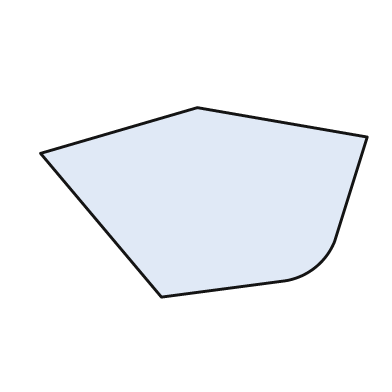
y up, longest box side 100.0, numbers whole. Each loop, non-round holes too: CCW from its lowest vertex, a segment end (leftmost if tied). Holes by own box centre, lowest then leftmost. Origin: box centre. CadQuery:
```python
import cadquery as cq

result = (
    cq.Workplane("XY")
    .moveTo(-13.0, -29.0)
    .lineTo(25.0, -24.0)
    .threePointArc((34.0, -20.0), (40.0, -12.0))
    .lineTo(50.0, 20.0)
    .lineTo(-2.0, 29.0)
    .lineTo(-50.0, 15.0)
    .close()
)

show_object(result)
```